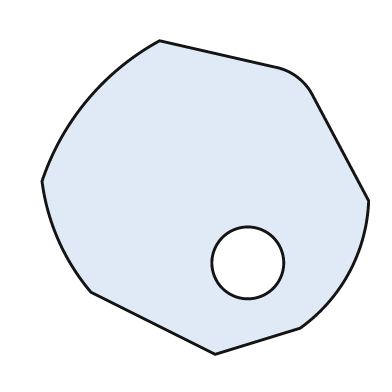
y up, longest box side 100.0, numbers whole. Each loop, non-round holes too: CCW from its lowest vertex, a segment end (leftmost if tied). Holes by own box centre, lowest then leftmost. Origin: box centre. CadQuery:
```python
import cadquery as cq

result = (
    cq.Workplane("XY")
    .moveTo(3.0, -48.0)
    .lineTo(29.0, -40.0)
    .threePointArc((44.0, -23.0), (50.0, -1.0))
    .lineTo(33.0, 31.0)
    .threePointArc((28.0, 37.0), (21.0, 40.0))
    .lineTo(-14.0, 48.0)
    .threePointArc((-36.0, 30.0), (-50.0, 5.0))
    .threePointArc((-45.0, -13.0), (-35.0, -29.0))
    .close()
    .moveTo(13.0, -20.0)
    .circle(11.0)
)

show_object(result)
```